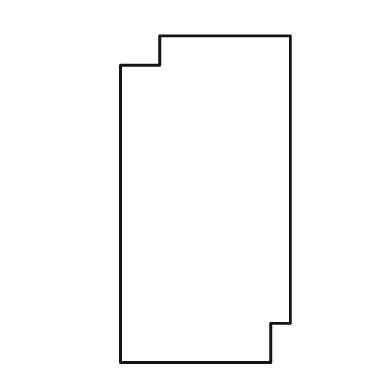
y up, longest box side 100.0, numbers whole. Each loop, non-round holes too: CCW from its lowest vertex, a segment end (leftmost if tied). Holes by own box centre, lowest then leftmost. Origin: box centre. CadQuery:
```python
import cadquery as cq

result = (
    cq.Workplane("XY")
    .moveTo(-26.0, -50.0)
    .lineTo(20.0, -50.0)
    .lineTo(20.0, -38.0)
    .lineTo(26.0, -38.0)
    .lineTo(26.0, 50.0)
    .lineTo(-14.0, 50.0)
    .lineTo(-14.0, 41.0)
    .lineTo(-26.0, 41.0)
    .close()
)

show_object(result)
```